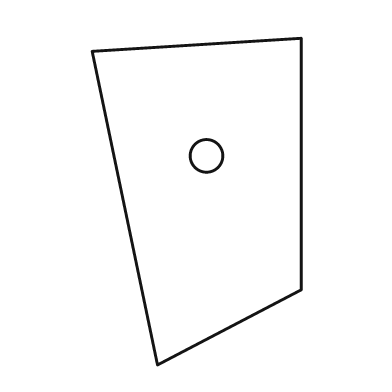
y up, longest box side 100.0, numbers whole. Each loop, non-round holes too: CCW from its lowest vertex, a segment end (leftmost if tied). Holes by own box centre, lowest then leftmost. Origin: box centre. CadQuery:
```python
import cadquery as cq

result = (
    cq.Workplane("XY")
    .moveTo(-12.0, -50.0)
    .lineTo(32.0, -27.0)
    .lineTo(32.0, 50.0)
    .lineTo(-32.0, 46.0)
    .close()
    .moveTo(3.0, 14.0)
    .circle(5.0)
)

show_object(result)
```